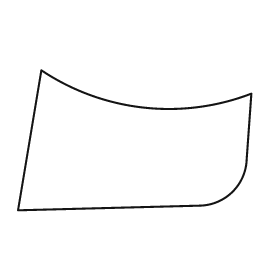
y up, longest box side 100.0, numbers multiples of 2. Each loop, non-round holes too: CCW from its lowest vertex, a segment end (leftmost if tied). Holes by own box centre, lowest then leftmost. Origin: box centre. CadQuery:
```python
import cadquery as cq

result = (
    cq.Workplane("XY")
    .moveTo(-50.0, -30.0)
    .lineTo(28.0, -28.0)
    .threePointArc((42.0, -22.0), (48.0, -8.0))
    .lineTo(50.0, 20.0)
    .threePointArc((4.0, 14.0), (-40.0, 30.0))
    .close()
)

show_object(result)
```